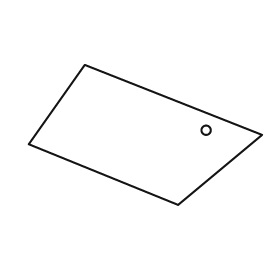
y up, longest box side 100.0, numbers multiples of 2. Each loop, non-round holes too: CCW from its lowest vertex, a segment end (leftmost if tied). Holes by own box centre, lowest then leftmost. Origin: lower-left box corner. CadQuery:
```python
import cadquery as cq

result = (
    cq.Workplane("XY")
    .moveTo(64.0, 0.0)
    .lineTo(100.0, 30.0)
    .lineTo(24.0, 60.0)
    .lineTo(0.0, 26.0)
    .close()
    .moveTo(76.0, 32.0)
    .circle(2.0)
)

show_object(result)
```